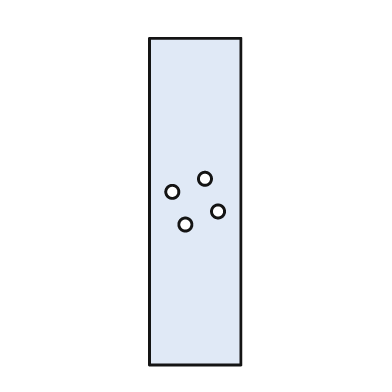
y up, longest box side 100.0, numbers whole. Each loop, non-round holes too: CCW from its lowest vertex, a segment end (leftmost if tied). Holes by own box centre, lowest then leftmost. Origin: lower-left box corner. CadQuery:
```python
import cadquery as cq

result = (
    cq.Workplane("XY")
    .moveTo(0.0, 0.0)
    .lineTo(28.0, 0.0)
    .lineTo(28.0, 100.0)
    .lineTo(0.0, 100.0)
    .close()
    .moveTo(11.0, 43.0)
    .circle(2.0)
    .moveTo(21.0, 47.0)
    .circle(2.0)
    .moveTo(7.0, 53.0)
    .circle(2.0)
    .moveTo(17.0, 57.0)
    .circle(2.0)
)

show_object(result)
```